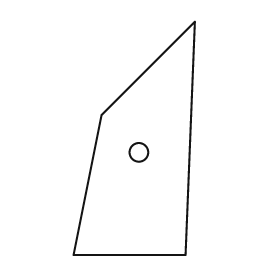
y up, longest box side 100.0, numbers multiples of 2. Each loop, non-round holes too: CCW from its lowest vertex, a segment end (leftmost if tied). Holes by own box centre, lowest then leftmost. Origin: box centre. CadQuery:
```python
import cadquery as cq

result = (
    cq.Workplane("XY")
    .moveTo(-26.0, -50.0)
    .lineTo(22.0, -50.0)
    .lineTo(26.0, 50.0)
    .lineTo(-14.0, 10.0)
    .close()
    .moveTo(2.0, -6.0)
    .circle(4.0)
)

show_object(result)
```